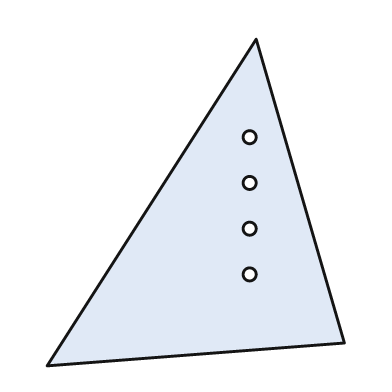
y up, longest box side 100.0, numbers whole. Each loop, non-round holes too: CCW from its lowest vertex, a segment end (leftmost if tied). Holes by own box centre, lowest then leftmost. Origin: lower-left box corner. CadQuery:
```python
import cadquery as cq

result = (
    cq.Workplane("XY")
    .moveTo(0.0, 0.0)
    .lineTo(91.0, 7.0)
    .lineTo(64.0, 100.0)
    .close()
    .moveTo(62.0, 28.0)
    .circle(2.0)
    .moveTo(62.0, 42.0)
    .circle(2.0)
    .moveTo(62.0, 56.0)
    .circle(2.0)
    .moveTo(62.0, 70.0)
    .circle(2.0)
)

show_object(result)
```